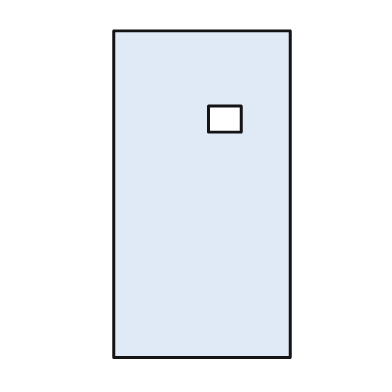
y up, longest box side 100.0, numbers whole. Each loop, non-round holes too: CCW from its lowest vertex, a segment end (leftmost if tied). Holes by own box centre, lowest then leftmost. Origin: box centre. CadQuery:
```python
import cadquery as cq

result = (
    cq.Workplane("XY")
    .moveTo(-27.0, -50.0)
    .lineTo(27.0, -50.0)
    .lineTo(27.0, 50.0)
    .lineTo(-27.0, 50.0)
    .close()
    .moveTo(2.0, 19.0)
    .lineTo(12.0, 19.0)
    .lineTo(12.0, 27.0)
    .lineTo(2.0, 27.0)
    .close()
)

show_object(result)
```